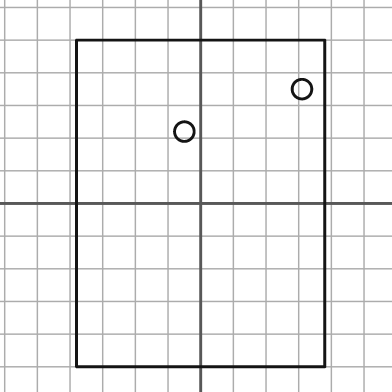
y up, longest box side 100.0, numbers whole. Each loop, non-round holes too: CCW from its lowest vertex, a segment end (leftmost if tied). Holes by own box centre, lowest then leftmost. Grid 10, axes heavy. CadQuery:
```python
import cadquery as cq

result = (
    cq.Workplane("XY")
    .moveTo(-38.0, -50.0)
    .lineTo(38.0, -50.0)
    .lineTo(38.0, 50.0)
    .lineTo(-38.0, 50.0)
    .close()
    .moveTo(-5.0, 22.0)
    .circle(3.0)
    .moveTo(31.0, 35.0)
    .circle(3.0)
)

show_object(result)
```